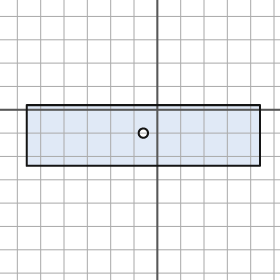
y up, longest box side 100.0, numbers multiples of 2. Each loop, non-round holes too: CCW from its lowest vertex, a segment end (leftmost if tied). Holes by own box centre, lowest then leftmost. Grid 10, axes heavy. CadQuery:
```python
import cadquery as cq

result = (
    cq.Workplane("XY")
    .moveTo(-56.0, -24.0)
    .lineTo(44.0, -24.0)
    .lineTo(44.0, 2.0)
    .lineTo(-56.0, 2.0)
    .close()
    .moveTo(-6.0, -10.0)
    .circle(2.0)
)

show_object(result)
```